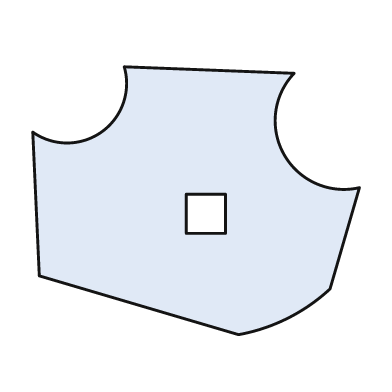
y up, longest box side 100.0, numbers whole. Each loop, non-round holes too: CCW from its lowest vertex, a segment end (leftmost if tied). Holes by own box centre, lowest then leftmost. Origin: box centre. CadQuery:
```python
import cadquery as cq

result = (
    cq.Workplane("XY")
    .moveTo(13.0, -41.0)
    .threePointArc((28.0, -36.0), (41.0, -27.0))
    .lineTo(50.0, 4.0)
    .threePointArc((27.0, 14.0), (30.0, 39.0))
    .lineTo(-22.0, 41.0)
    .threePointArc((-29.0, 21.0), (-50.0, 21.0))
    .lineTo(-48.0, -23.0)
    .close()
    .moveTo(-3.0, -10.0)
    .lineTo(9.0, -10.0)
    .lineTo(9.0, 2.0)
    .lineTo(-3.0, 2.0)
    .close()
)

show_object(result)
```